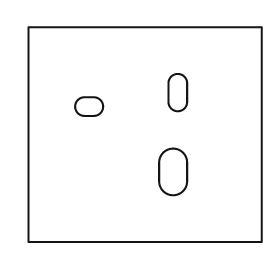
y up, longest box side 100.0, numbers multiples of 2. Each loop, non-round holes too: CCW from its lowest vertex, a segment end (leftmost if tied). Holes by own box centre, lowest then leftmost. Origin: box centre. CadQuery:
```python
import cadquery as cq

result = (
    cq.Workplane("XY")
    .moveTo(-50.0, -46.0)
    .lineTo(50.0, -46.0)
    .lineTo(50.0, 46.0)
    .lineTo(-50.0, 46.0)
    .close()
    .moveTo(6.0, -20.0)
    .threePointArc((12.0, -26.0), (18.0, -20.0))
    .lineTo(18.0, -12.0)
    .threePointArc((12.0, -6.0), (6.0, -12.0))
    .close()
    .moveTo(-26.0, 8.0)
    .lineTo(-22.0, 8.0)
    .threePointArc((-18.0, 12.0), (-22.0, 16.0))
    .lineTo(-26.0, 16.0)
    .threePointArc((-30.0, 12.0), (-26.0, 8.0))
    .close()
    .moveTo(10.0, 14.0)
    .threePointArc((14.0, 10.0), (18.0, 14.0))
    .lineTo(18.0, 22.0)
    .threePointArc((14.0, 26.0), (10.0, 22.0))
    .close()
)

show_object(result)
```